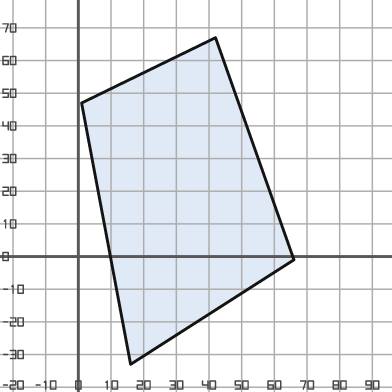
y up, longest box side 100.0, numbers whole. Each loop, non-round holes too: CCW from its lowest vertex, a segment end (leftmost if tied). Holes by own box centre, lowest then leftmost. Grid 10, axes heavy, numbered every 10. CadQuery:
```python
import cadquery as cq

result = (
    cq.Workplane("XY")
    .moveTo(16.0, -33.0)
    .lineTo(66.0, -1.0)
    .lineTo(42.0, 67.0)
    .lineTo(1.0, 47.0)
    .close()
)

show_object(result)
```